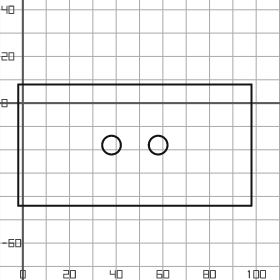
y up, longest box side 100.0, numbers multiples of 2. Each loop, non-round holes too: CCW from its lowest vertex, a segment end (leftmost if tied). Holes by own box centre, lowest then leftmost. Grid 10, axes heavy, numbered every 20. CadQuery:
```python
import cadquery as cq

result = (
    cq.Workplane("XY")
    .moveTo(-2.0, -44.0)
    .lineTo(98.0, -44.0)
    .lineTo(98.0, 8.0)
    .lineTo(-2.0, 8.0)
    .close()
    .moveTo(38.0, -18.0)
    .circle(4.0)
    .moveTo(58.0, -18.0)
    .circle(4.0)
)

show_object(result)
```